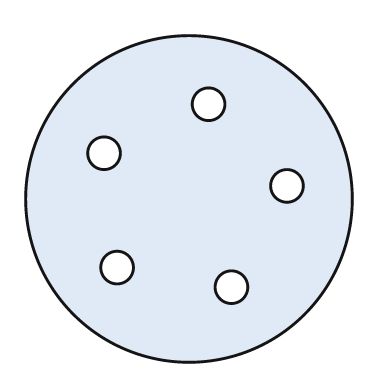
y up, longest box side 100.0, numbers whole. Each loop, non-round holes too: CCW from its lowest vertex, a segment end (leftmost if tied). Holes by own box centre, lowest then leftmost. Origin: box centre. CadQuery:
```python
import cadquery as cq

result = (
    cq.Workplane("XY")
    .moveTo(0.0, 0.0)
    .circle(50.0)
    .moveTo(13.0, -27.0)
    .circle(5.0)
    .moveTo(-22.0, -21.0)
    .circle(5.0)
    .moveTo(30.0, 4.0)
    .circle(5.0)
    .moveTo(-26.0, 14.0)
    .circle(5.0)
    .moveTo(6.0, 29.0)
    .circle(5.0)
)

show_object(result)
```